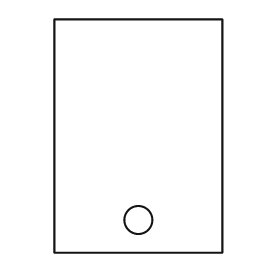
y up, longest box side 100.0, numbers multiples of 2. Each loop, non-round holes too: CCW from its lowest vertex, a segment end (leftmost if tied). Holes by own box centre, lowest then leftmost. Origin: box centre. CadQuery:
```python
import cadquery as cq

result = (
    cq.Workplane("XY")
    .moveTo(-36.0, -50.0)
    .lineTo(36.0, -50.0)
    .lineTo(36.0, 50.0)
    .lineTo(-36.0, 50.0)
    .close()
    .moveTo(0.0, -36.0)
    .circle(6.0)
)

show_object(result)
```